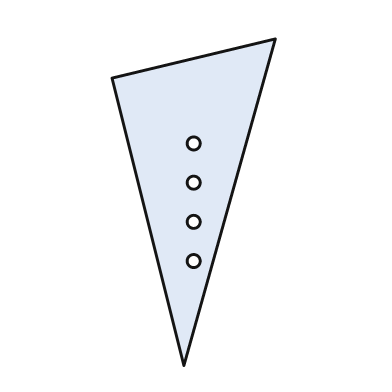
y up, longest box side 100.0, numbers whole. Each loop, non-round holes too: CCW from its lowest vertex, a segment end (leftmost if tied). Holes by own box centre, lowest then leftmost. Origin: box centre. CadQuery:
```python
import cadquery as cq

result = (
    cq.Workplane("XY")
    .moveTo(-3.0, -50.0)
    .lineTo(25.0, 50.0)
    .lineTo(-25.0, 38.0)
    .close()
    .moveTo(0.0, -18.0)
    .circle(2.0)
    .moveTo(0.0, -6.0)
    .circle(2.0)
    .moveTo(0.0, 6.0)
    .circle(2.0)
    .moveTo(0.0, 18.0)
    .circle(2.0)
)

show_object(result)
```